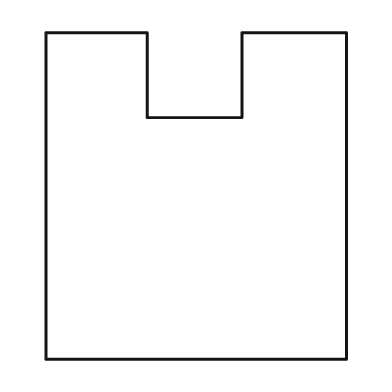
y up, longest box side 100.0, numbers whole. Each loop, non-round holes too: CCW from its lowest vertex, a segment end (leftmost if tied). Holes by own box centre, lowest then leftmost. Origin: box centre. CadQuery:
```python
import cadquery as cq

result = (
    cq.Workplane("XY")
    .moveTo(-46.0, -50.0)
    .lineTo(46.0, -50.0)
    .lineTo(46.0, 50.0)
    .lineTo(14.0, 50.0)
    .lineTo(14.0, 24.0)
    .lineTo(-15.0, 24.0)
    .lineTo(-15.0, 50.0)
    .lineTo(-46.0, 50.0)
    .close()
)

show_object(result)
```